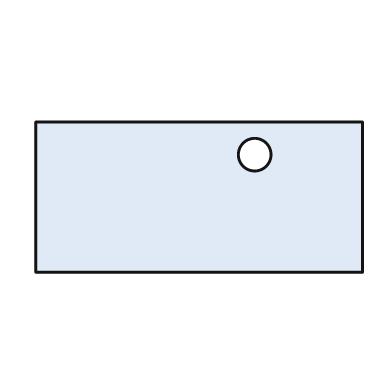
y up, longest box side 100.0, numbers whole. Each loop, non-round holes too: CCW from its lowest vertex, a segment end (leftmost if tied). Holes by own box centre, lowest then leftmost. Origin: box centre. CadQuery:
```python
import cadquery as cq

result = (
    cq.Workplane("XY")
    .moveTo(-50.0, -23.0)
    .lineTo(50.0, -23.0)
    .lineTo(50.0, 23.0)
    .lineTo(-50.0, 23.0)
    .close()
    .moveTo(17.0, 13.0)
    .circle(5.0)
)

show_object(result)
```